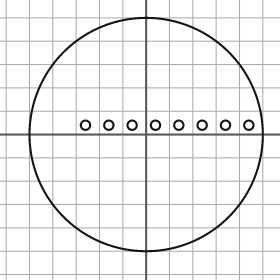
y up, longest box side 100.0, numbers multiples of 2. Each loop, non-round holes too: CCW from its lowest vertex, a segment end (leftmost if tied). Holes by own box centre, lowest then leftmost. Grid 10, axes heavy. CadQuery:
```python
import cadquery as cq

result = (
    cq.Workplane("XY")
    .moveTo(0.0, 0.0)
    .circle(50.0)
    .moveTo(-26.0, 4.0)
    .circle(2.0)
    .moveTo(-16.0, 4.0)
    .circle(2.0)
    .moveTo(-6.0, 4.0)
    .circle(2.0)
    .moveTo(4.0, 4.0)
    .circle(2.0)
    .moveTo(14.0, 4.0)
    .circle(2.0)
    .moveTo(24.0, 4.0)
    .circle(2.0)
    .moveTo(34.0, 4.0)
    .circle(2.0)
    .moveTo(44.0, 4.0)
    .circle(2.0)
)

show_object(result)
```